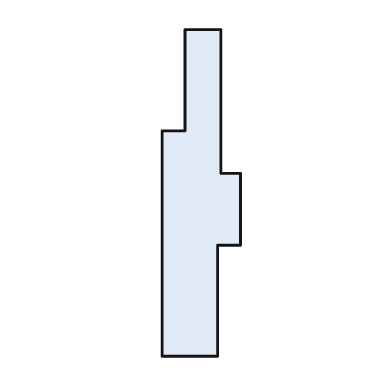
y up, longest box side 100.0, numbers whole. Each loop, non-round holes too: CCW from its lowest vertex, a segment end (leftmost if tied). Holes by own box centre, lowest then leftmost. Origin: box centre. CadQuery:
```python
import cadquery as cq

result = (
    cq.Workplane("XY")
    .moveTo(-12.0, -50.0)
    .lineTo(5.0, -50.0)
    .lineTo(5.0, -16.0)
    .lineTo(12.0, -16.0)
    .lineTo(12.0, 6.0)
    .lineTo(6.0, 6.0)
    .lineTo(6.0, 50.0)
    .lineTo(-5.0, 50.0)
    .lineTo(-5.0, 19.0)
    .lineTo(-12.0, 19.0)
    .close()
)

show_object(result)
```